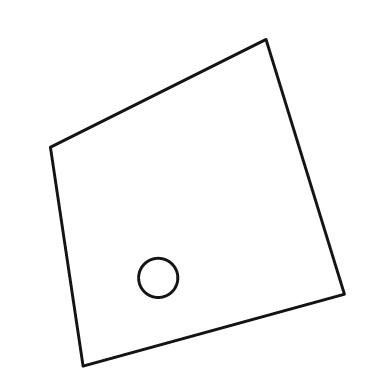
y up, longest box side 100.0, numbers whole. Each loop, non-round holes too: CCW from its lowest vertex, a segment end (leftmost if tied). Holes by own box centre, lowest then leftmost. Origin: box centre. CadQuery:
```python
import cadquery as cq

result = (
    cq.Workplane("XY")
    .moveTo(-35.0, -50.0)
    .lineTo(45.0, -28.0)
    .lineTo(21.0, 50.0)
    .lineTo(-45.0, 17.0)
    .close()
    .moveTo(-12.0, -23.0)
    .circle(6.0)
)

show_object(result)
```